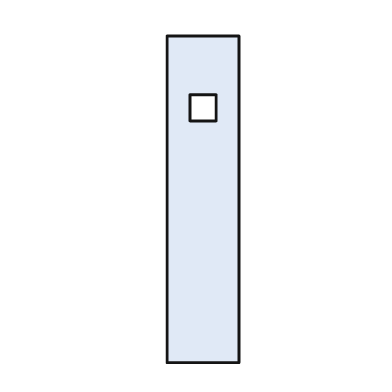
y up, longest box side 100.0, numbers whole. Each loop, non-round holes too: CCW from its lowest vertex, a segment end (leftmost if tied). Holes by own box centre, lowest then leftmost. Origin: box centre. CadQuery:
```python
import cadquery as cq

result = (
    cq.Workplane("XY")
    .moveTo(-11.0, -50.0)
    .lineTo(11.0, -50.0)
    .lineTo(11.0, 50.0)
    .lineTo(-11.0, 50.0)
    .close()
    .moveTo(-4.0, 24.0)
    .lineTo(4.0, 24.0)
    .lineTo(4.0, 32.0)
    .lineTo(-4.0, 32.0)
    .close()
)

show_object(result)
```